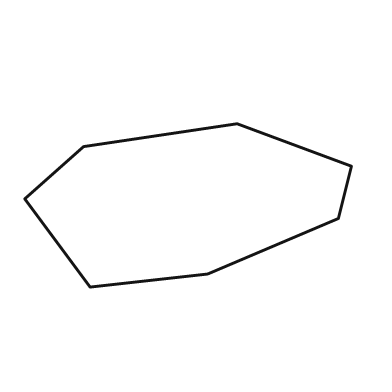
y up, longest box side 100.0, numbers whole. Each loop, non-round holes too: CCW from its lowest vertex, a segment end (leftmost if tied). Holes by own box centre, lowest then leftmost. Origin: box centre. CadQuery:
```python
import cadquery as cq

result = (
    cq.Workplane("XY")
    .moveTo(-30.0, -25.0)
    .lineTo(6.0, -21.0)
    .lineTo(46.0, -4.0)
    .lineTo(50.0, 12.0)
    .lineTo(15.0, 25.0)
    .lineTo(-32.0, 18.0)
    .lineTo(-50.0, 2.0)
    .close()
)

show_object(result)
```